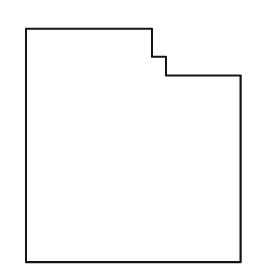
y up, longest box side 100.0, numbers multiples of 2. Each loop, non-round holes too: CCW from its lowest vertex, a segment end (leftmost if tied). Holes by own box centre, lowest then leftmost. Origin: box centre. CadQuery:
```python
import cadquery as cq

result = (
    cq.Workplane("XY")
    .moveTo(-46.0, -50.0)
    .lineTo(46.0, -50.0)
    .lineTo(46.0, 30.0)
    .lineTo(14.0, 30.0)
    .lineTo(14.0, 38.0)
    .lineTo(8.0, 38.0)
    .lineTo(8.0, 50.0)
    .lineTo(-46.0, 50.0)
    .close()
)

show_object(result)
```